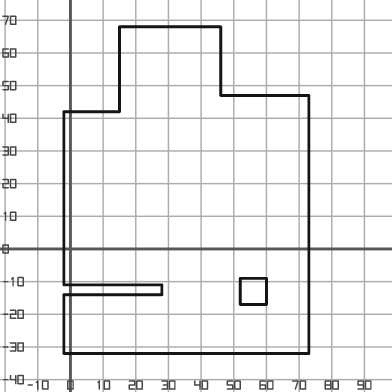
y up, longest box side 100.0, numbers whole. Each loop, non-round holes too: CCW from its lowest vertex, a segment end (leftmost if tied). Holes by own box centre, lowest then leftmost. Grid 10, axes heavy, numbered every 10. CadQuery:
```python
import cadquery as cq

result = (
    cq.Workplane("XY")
    .moveTo(-2.0, -32.0)
    .lineTo(73.0, -32.0)
    .lineTo(73.0, 47.0)
    .lineTo(46.0, 47.0)
    .lineTo(46.0, 68.0)
    .lineTo(15.0, 68.0)
    .lineTo(15.0, 42.0)
    .lineTo(-2.0, 42.0)
    .lineTo(-2.0, -11.0)
    .lineTo(28.0, -11.0)
    .lineTo(28.0, -14.0)
    .lineTo(-2.0, -14.0)
    .close()
    .moveTo(52.0, -17.0)
    .lineTo(60.0, -17.0)
    .lineTo(60.0, -9.0)
    .lineTo(52.0, -9.0)
    .close()
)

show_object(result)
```